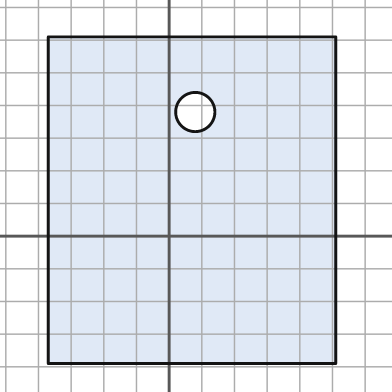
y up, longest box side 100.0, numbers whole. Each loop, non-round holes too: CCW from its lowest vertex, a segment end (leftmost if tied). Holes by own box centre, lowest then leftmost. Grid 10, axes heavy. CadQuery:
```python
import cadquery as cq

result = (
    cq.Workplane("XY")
    .moveTo(-37.0, -39.0)
    .lineTo(51.0, -39.0)
    .lineTo(51.0, 61.0)
    .lineTo(-37.0, 61.0)
    .close()
    .moveTo(8.0, 38.0)
    .circle(6.0)
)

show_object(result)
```